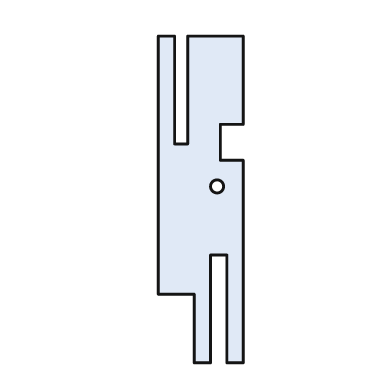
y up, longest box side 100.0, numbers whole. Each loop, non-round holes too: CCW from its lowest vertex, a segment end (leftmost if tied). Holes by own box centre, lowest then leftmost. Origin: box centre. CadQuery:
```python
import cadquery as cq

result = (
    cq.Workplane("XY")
    .moveTo(-2.0, -50.0)
    .lineTo(3.0, -50.0)
    .lineTo(3.0, -17.0)
    .lineTo(8.0, -17.0)
    .lineTo(8.0, -50.0)
    .lineTo(13.0, -50.0)
    .lineTo(13.0, 12.0)
    .lineTo(6.0, 12.0)
    .lineTo(6.0, 23.0)
    .lineTo(13.0, 23.0)
    .lineTo(13.0, 50.0)
    .lineTo(-4.0, 50.0)
    .lineTo(-4.0, 17.0)
    .lineTo(-8.0, 17.0)
    .lineTo(-8.0, 50.0)
    .lineTo(-13.0, 50.0)
    .lineTo(-13.0, -29.0)
    .lineTo(-2.0, -29.0)
    .close()
    .moveTo(5.0, 4.0)
    .circle(2.0)
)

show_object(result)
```